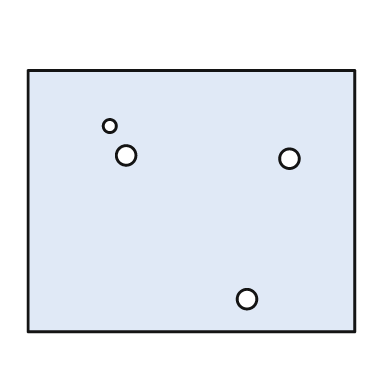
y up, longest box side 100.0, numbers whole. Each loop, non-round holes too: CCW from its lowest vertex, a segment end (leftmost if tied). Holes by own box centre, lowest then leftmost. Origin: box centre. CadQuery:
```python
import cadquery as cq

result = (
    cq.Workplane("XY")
    .moveTo(-50.0, -40.0)
    .lineTo(50.0, -40.0)
    .lineTo(50.0, 40.0)
    .lineTo(-50.0, 40.0)
    .close()
    .moveTo(17.0, -30.0)
    .circle(3.0)
    .moveTo(30.0, 13.0)
    .circle(3.0)
    .moveTo(-20.0, 14.0)
    .circle(3.0)
    .moveTo(-25.0, 23.0)
    .circle(2.0)
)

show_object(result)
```